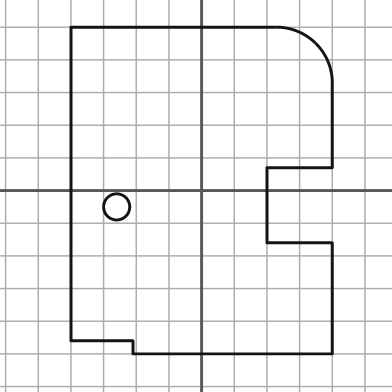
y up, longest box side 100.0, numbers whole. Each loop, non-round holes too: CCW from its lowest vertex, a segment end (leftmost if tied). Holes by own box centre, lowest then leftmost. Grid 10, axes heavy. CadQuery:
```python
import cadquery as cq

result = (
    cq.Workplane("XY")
    .moveTo(-21.0, -50.0)
    .lineTo(40.0, -50.0)
    .lineTo(40.0, -16.0)
    .lineTo(20.0, -16.0)
    .lineTo(20.0, 7.0)
    .lineTo(40.0, 7.0)
    .lineTo(40.0, 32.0)
    .threePointArc((35.0, 45.0), (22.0, 50.0))
    .lineTo(-40.0, 50.0)
    .lineTo(-40.0, -46.0)
    .lineTo(-21.0, -46.0)
    .close()
    .moveTo(-26.0, -5.0)
    .circle(4.0)
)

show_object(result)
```